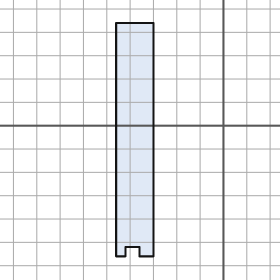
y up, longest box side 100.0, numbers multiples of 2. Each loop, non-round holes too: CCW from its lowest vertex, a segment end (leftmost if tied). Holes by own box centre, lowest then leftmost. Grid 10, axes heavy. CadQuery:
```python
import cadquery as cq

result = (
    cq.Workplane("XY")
    .moveTo(-46.0, -56.0)
    .lineTo(-42.0, -56.0)
    .lineTo(-42.0, -52.0)
    .lineTo(-36.0, -52.0)
    .lineTo(-36.0, -56.0)
    .lineTo(-30.0, -56.0)
    .lineTo(-30.0, 44.0)
    .lineTo(-46.0, 44.0)
    .close()
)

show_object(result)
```